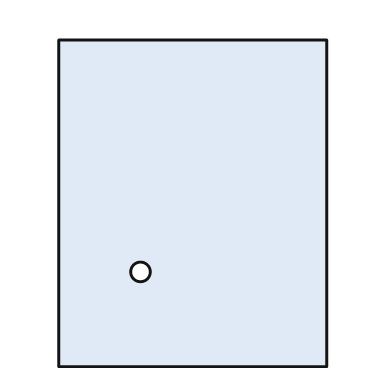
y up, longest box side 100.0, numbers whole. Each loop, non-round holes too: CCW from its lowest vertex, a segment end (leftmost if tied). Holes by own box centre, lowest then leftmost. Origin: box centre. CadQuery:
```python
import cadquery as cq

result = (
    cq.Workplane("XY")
    .moveTo(-41.0, -50.0)
    .lineTo(41.0, -50.0)
    .lineTo(41.0, 50.0)
    .lineTo(-41.0, 50.0)
    .close()
    .moveTo(-16.0, -21.0)
    .circle(3.0)
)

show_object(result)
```